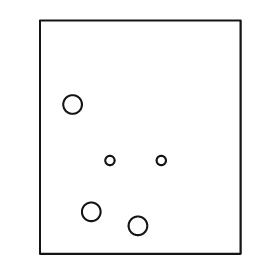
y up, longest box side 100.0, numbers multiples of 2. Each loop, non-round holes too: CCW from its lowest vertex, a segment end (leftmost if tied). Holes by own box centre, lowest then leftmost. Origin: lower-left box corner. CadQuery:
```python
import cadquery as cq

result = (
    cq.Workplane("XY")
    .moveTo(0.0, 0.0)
    .lineTo(86.0, 0.0)
    .lineTo(86.0, 100.0)
    .lineTo(0.0, 100.0)
    .close()
    .moveTo(42.0, 12.0)
    .circle(4.0)
    .moveTo(22.0, 18.0)
    .circle(4.0)
    .moveTo(30.0, 40.0)
    .circle(2.0)
    .moveTo(52.0, 40.0)
    .circle(2.0)
    .moveTo(14.0, 64.0)
    .circle(4.0)
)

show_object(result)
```